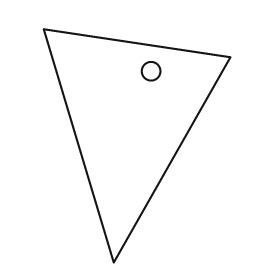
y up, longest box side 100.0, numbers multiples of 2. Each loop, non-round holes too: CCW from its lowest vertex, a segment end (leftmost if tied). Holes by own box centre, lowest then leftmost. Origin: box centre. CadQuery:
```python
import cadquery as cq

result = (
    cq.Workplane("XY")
    .moveTo(-10.0, -50.0)
    .lineTo(40.0, 38.0)
    .lineTo(-40.0, 50.0)
    .close()
    .moveTo(6.0, 32.0)
    .circle(4.0)
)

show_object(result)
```